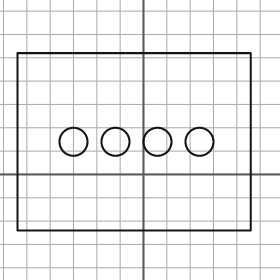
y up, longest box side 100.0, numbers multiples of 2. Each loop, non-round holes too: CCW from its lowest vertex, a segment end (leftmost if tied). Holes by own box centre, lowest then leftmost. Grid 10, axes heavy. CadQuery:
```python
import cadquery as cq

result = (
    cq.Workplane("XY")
    .moveTo(-54.0, -24.0)
    .lineTo(46.0, -24.0)
    .lineTo(46.0, 52.0)
    .lineTo(-54.0, 52.0)
    .close()
    .moveTo(-30.0, 14.0)
    .circle(6.0)
    .moveTo(-12.0, 14.0)
    .circle(6.0)
    .moveTo(6.0, 14.0)
    .circle(6.0)
    .moveTo(24.0, 14.0)
    .circle(6.0)
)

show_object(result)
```